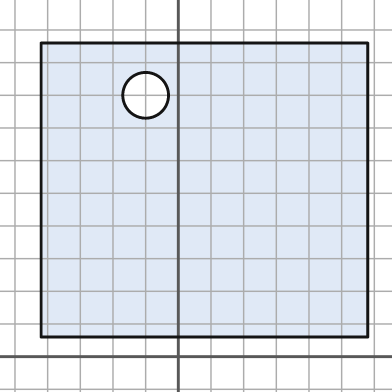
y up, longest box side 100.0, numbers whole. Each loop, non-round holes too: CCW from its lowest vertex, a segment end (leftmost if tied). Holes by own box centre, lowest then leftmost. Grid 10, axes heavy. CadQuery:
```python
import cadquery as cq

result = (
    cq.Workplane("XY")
    .moveTo(-42.0, 6.0)
    .lineTo(58.0, 6.0)
    .lineTo(58.0, 96.0)
    .lineTo(-42.0, 96.0)
    .close()
    .moveTo(-10.0, 80.0)
    .circle(7.0)
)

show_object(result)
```